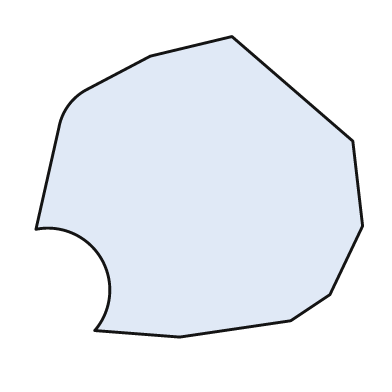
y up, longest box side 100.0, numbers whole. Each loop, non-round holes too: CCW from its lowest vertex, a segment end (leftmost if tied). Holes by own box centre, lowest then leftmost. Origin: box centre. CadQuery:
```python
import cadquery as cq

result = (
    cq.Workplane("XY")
    .moveTo(-6.0, -46.0)
    .lineTo(28.0, -41.0)
    .lineTo(40.0, -33.0)
    .lineTo(50.0, -12.0)
    .lineTo(47.0, 14.0)
    .lineTo(10.0, 46.0)
    .lineTo(-15.0, 40.0)
    .lineTo(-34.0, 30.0)
    .threePointArc((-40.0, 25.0), (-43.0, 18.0))
    .lineTo(-50.0, -13.0)
    .threePointArc((-30.0, -22.0), (-32.0, -44.0))
    .close()
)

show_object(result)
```